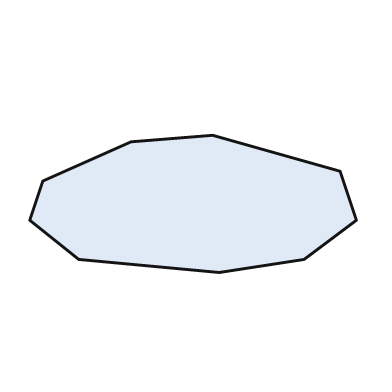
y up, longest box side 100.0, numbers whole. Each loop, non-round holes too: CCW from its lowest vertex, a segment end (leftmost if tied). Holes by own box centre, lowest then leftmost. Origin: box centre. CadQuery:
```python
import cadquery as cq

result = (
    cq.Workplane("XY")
    .moveTo(8.0, -21.0)
    .lineTo(34.0, -17.0)
    .lineTo(50.0, -5.0)
    .lineTo(45.0, 10.0)
    .lineTo(6.0, 21.0)
    .lineTo(-19.0, 19.0)
    .lineTo(-46.0, 7.0)
    .lineTo(-50.0, -5.0)
    .lineTo(-35.0, -17.0)
    .close()
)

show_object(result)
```